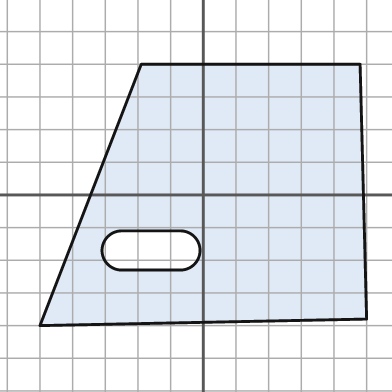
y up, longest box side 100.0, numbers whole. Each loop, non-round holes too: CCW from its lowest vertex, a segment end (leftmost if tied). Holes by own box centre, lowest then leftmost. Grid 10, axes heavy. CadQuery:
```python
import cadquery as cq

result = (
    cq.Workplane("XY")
    .moveTo(-50.0, -40.0)
    .lineTo(50.0, -38.0)
    .lineTo(48.0, 40.0)
    .lineTo(-19.0, 40.0)
    .close()
    .moveTo(-25.0, -23.0)
    .lineTo(-7.0, -23.0)
    .threePointArc((-1.0, -17.0), (-7.0, -11.0))
    .lineTo(-25.0, -11.0)
    .threePointArc((-31.0, -17.0), (-25.0, -23.0))
    .close()
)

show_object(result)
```